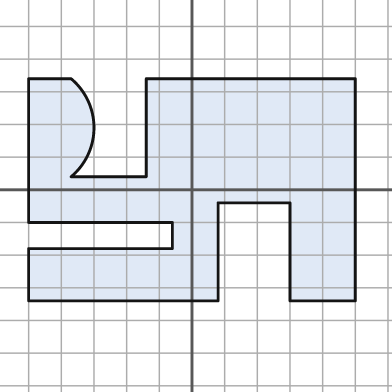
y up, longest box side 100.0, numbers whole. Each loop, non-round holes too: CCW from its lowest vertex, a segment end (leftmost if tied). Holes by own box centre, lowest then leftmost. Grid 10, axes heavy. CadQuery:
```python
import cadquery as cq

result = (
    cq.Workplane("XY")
    .moveTo(-50.0, -34.0)
    .lineTo(8.0, -34.0)
    .lineTo(8.0, -4.0)
    .lineTo(30.0, -4.0)
    .lineTo(30.0, -34.0)
    .lineTo(50.0, -34.0)
    .lineTo(50.0, 34.0)
    .lineTo(-14.0, 34.0)
    .lineTo(-14.0, 4.0)
    .lineTo(-37.0, 4.0)
    .threePointArc((-30.0, 19.0), (-37.0, 34.0))
    .lineTo(-50.0, 34.0)
    .lineTo(-50.0, -10.0)
    .lineTo(-6.0, -10.0)
    .lineTo(-6.0, -18.0)
    .lineTo(-50.0, -18.0)
    .close()
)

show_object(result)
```